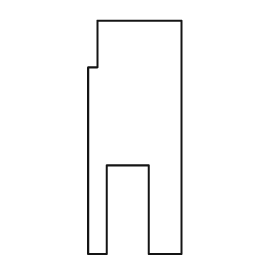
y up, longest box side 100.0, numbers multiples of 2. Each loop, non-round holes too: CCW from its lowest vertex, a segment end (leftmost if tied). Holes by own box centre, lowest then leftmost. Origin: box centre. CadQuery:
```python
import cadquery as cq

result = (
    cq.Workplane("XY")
    .moveTo(-20.0, -50.0)
    .lineTo(-12.0, -50.0)
    .lineTo(-12.0, -12.0)
    .lineTo(6.0, -12.0)
    .lineTo(6.0, -50.0)
    .lineTo(20.0, -50.0)
    .lineTo(20.0, 50.0)
    .lineTo(-16.0, 50.0)
    .lineTo(-16.0, 30.0)
    .lineTo(-20.0, 30.0)
    .close()
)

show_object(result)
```